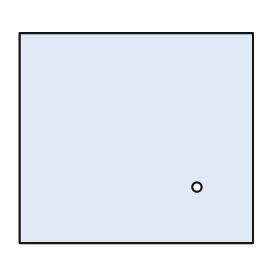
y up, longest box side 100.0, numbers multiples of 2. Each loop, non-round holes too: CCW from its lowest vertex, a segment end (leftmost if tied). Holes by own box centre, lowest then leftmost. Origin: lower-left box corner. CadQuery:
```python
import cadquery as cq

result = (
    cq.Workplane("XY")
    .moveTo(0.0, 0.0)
    .lineTo(100.0, 0.0)
    .lineTo(100.0, 90.0)
    .lineTo(0.0, 90.0)
    .close()
    .moveTo(76.0, 24.0)
    .circle(2.0)
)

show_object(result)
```